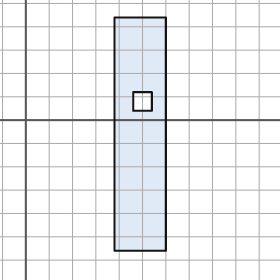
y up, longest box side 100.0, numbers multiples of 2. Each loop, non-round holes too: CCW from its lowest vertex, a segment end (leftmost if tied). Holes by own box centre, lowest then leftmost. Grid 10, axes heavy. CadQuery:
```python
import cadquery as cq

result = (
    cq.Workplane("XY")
    .moveTo(38.0, -56.0)
    .lineTo(60.0, -56.0)
    .lineTo(60.0, 44.0)
    .lineTo(38.0, 44.0)
    .close()
    .moveTo(46.0, 4.0)
    .lineTo(54.0, 4.0)
    .lineTo(54.0, 12.0)
    .lineTo(46.0, 12.0)
    .close()
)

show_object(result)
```